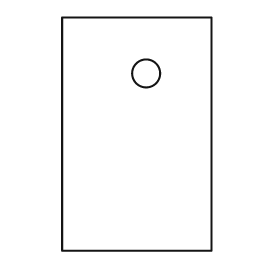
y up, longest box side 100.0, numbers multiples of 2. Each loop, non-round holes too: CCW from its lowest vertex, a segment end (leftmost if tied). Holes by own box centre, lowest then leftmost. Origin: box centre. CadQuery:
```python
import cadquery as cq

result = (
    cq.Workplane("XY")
    .moveTo(-32.0, -50.0)
    .lineTo(32.0, -50.0)
    .lineTo(32.0, 50.0)
    .lineTo(-32.0, 50.0)
    .close()
    .moveTo(4.0, 26.0)
    .circle(6.0)
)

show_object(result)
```